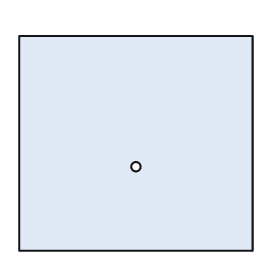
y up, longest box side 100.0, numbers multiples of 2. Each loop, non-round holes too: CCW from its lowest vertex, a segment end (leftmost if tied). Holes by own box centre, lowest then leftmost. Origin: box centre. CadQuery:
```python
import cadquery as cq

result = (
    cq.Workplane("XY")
    .moveTo(-50.0, -46.0)
    .lineTo(50.0, -46.0)
    .lineTo(50.0, 46.0)
    .lineTo(-50.0, 46.0)
    .close()
    .moveTo(0.0, -10.0)
    .circle(2.0)
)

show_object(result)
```